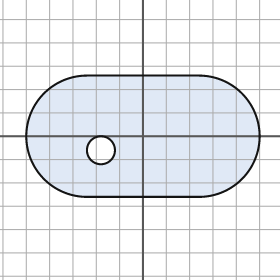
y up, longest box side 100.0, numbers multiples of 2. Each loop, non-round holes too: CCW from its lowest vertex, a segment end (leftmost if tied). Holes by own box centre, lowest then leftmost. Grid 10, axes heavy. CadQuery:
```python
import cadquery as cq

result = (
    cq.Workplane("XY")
    .moveTo(-24.0, -26.0)
    .lineTo(24.0, -26.0)
    .threePointArc((50.0, 0.0), (24.0, 26.0))
    .lineTo(-24.0, 26.0)
    .threePointArc((-50.0, 0.0), (-24.0, -26.0))
    .close()
    .moveTo(-18.0, -6.0)
    .circle(6.0)
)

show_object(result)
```